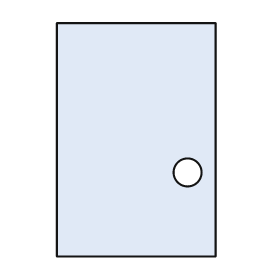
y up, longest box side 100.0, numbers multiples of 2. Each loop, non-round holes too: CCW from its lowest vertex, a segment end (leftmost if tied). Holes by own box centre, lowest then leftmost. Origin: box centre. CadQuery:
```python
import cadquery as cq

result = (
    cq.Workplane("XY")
    .moveTo(-34.0, -50.0)
    .lineTo(34.0, -50.0)
    .lineTo(34.0, 50.0)
    .lineTo(-34.0, 50.0)
    .close()
    .moveTo(22.0, -14.0)
    .circle(6.0)
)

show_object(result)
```